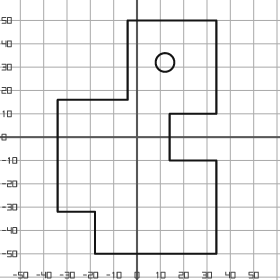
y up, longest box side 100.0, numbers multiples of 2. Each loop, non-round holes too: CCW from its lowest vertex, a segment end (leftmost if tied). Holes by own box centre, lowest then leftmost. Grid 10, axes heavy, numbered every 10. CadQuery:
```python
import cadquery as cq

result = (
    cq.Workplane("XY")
    .moveTo(-18.0, -50.0)
    .lineTo(34.0, -50.0)
    .lineTo(34.0, -10.0)
    .lineTo(14.0, -10.0)
    .lineTo(14.0, 10.0)
    .lineTo(34.0, 10.0)
    .lineTo(34.0, 50.0)
    .lineTo(-4.0, 50.0)
    .lineTo(-4.0, 16.0)
    .lineTo(-34.0, 16.0)
    .lineTo(-34.0, -32.0)
    .lineTo(-18.0, -32.0)
    .close()
    .moveTo(12.0, 32.0)
    .circle(4.0)
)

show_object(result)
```